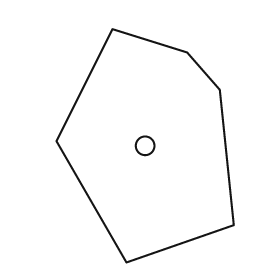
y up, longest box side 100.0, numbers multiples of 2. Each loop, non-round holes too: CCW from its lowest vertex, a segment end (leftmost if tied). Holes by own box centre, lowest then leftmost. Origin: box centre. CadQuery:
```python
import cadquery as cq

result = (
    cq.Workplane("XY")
    .moveTo(-8.0, -50.0)
    .lineTo(38.0, -34.0)
    .lineTo(32.0, 24.0)
    .lineTo(18.0, 40.0)
    .lineTo(-14.0, 50.0)
    .lineTo(-38.0, 2.0)
    .close()
    .moveTo(0.0, 0.0)
    .circle(4.0)
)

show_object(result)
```